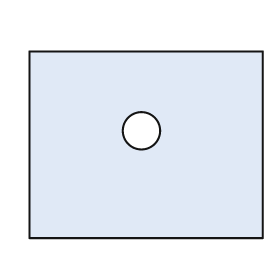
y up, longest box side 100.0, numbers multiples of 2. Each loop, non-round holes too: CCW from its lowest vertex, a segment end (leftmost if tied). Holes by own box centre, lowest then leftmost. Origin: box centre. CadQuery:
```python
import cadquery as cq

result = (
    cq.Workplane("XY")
    .moveTo(-50.0, -40.0)
    .lineTo(50.0, -40.0)
    .lineTo(50.0, 40.0)
    .lineTo(-50.0, 40.0)
    .close()
    .moveTo(-2.0, 6.0)
    .circle(8.0)
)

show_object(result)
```